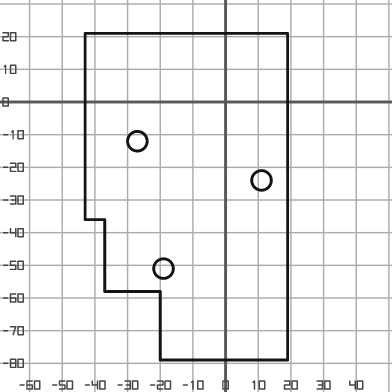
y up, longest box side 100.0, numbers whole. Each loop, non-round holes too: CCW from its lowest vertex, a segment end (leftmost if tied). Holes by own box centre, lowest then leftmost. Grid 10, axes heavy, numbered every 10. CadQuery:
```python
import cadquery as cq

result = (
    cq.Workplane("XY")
    .moveTo(-20.0, -79.0)
    .lineTo(19.0, -79.0)
    .lineTo(19.0, 21.0)
    .lineTo(-43.0, 21.0)
    .lineTo(-43.0, -36.0)
    .lineTo(-37.0, -36.0)
    .lineTo(-37.0, -58.0)
    .lineTo(-20.0, -58.0)
    .close()
    .moveTo(-19.0, -51.0)
    .circle(3.0)
    .moveTo(11.0, -24.0)
    .circle(3.0)
    .moveTo(-27.0, -12.0)
    .circle(3.0)
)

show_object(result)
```